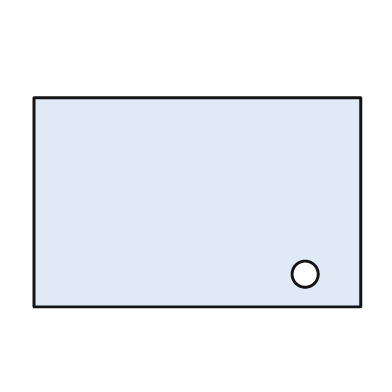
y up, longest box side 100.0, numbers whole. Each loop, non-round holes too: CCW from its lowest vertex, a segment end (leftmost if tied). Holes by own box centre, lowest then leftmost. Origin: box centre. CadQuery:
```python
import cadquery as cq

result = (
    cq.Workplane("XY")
    .moveTo(-50.0, -32.0)
    .lineTo(50.0, -32.0)
    .lineTo(50.0, 32.0)
    .lineTo(-50.0, 32.0)
    .close()
    .moveTo(33.0, -22.0)
    .circle(4.0)
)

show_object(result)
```